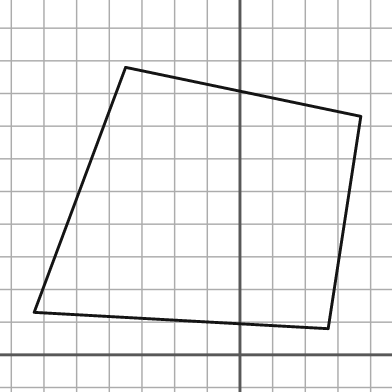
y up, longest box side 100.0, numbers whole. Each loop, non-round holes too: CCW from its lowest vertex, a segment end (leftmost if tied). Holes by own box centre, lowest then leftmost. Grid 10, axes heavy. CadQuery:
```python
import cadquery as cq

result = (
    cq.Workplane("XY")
    .moveTo(27.0, 8.0)
    .lineTo(37.0, 73.0)
    .lineTo(-35.0, 88.0)
    .lineTo(-63.0, 13.0)
    .close()
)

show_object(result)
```